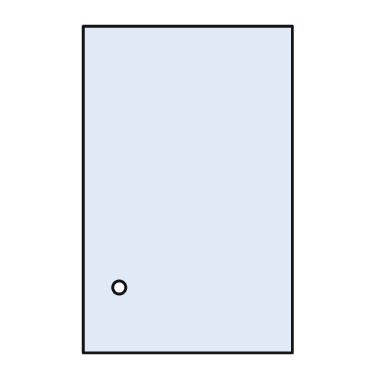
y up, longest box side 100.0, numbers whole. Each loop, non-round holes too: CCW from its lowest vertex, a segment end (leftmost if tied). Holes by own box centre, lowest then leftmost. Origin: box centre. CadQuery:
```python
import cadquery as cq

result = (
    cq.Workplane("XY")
    .moveTo(-32.0, -50.0)
    .lineTo(32.0, -50.0)
    .lineTo(32.0, 50.0)
    .lineTo(-32.0, 50.0)
    .close()
    .moveTo(-21.0, -30.0)
    .circle(2.0)
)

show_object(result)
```